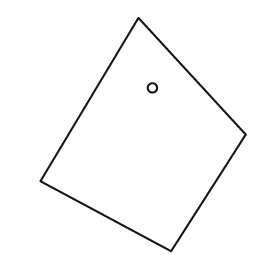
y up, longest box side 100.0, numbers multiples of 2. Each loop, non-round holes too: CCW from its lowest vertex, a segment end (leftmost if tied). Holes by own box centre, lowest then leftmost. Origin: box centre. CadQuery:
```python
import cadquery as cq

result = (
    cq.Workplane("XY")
    .moveTo(12.0, -50.0)
    .lineTo(44.0, 0.0)
    .lineTo(-2.0, 50.0)
    .lineTo(-44.0, -20.0)
    .close()
    .moveTo(4.0, 20.0)
    .circle(2.0)
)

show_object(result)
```